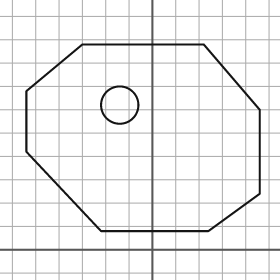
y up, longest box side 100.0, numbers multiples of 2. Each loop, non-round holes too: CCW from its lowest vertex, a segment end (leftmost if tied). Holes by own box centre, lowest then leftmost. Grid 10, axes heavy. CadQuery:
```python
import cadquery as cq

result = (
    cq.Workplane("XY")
    .moveTo(-22.0, 8.0)
    .lineTo(24.0, 8.0)
    .lineTo(46.0, 24.0)
    .lineTo(46.0, 60.0)
    .lineTo(22.0, 88.0)
    .lineTo(-30.0, 88.0)
    .lineTo(-54.0, 68.0)
    .lineTo(-54.0, 42.0)
    .close()
    .moveTo(-14.0, 62.0)
    .circle(8.0)
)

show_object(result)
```